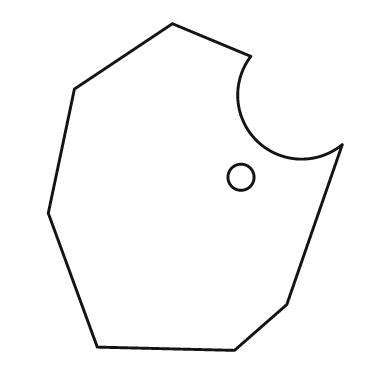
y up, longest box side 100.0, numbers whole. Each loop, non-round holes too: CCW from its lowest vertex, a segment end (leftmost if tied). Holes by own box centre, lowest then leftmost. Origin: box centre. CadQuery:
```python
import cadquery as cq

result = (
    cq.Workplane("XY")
    .moveTo(12.0, -50.0)
    .lineTo(28.0, -36.0)
    .lineTo(45.0, 13.0)
    .threePointArc((19.0, 14.0), (17.0, 40.0))
    .lineTo(-7.0, 50.0)
    .lineTo(-37.0, 30.0)
    .lineTo(-45.0, -8.0)
    .lineTo(-30.0, -49.0)
    .close()
    .moveTo(14.0, 3.0)
    .circle(4.0)
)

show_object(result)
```